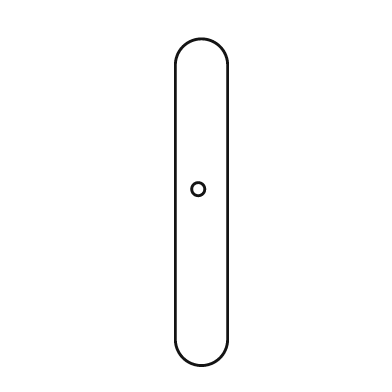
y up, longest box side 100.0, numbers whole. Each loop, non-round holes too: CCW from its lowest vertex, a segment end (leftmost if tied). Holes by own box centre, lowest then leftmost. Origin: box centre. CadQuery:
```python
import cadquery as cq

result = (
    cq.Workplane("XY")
    .moveTo(-8.0, -42.0)
    .threePointArc((0.0, -50.0), (8.0, -42.0))
    .lineTo(8.0, 42.0)
    .threePointArc((0.0, 50.0), (-8.0, 42.0))
    .close()
    .moveTo(-1.0, 4.0)
    .circle(2.0)
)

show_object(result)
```